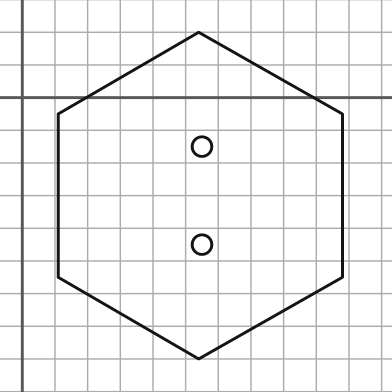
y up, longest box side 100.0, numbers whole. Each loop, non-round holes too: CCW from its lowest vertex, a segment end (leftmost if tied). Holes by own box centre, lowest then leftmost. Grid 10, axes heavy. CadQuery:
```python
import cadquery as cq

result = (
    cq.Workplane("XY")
    .moveTo(54.0, -80.0)
    .lineTo(98.0, -55.0)
    .lineTo(98.0, -5.0)
    .lineTo(54.0, 20.0)
    .lineTo(11.0, -5.0)
    .lineTo(11.0, -55.0)
    .close()
    .moveTo(55.0, -45.0)
    .circle(3.0)
    .moveTo(55.0, -15.0)
    .circle(3.0)
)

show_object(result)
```